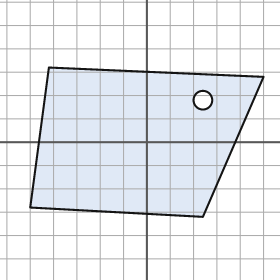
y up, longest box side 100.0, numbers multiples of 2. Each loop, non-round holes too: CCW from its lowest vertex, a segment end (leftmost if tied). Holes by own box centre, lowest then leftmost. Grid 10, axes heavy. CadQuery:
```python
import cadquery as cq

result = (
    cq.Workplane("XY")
    .moveTo(24.0, -32.0)
    .lineTo(50.0, 28.0)
    .lineTo(-42.0, 32.0)
    .lineTo(-50.0, -28.0)
    .close()
    .moveTo(24.0, 18.0)
    .circle(4.0)
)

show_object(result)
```